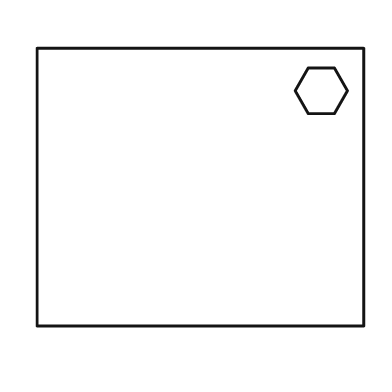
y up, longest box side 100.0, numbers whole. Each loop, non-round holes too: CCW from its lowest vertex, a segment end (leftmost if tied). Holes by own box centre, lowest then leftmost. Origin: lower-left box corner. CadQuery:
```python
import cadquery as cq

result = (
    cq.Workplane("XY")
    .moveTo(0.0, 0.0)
    .lineTo(100.0, 0.0)
    .lineTo(100.0, 85.0)
    .lineTo(0.0, 85.0)
    .close()
    .moveTo(83.0, 65.0)
    .lineTo(91.0, 65.0)
    .lineTo(95.0, 72.0)
    .lineTo(91.0, 79.0)
    .lineTo(83.0, 79.0)
    .lineTo(79.0, 72.0)
    .close()
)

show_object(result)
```